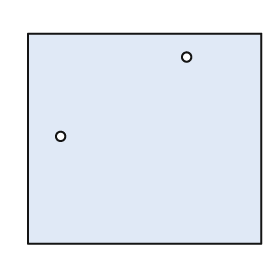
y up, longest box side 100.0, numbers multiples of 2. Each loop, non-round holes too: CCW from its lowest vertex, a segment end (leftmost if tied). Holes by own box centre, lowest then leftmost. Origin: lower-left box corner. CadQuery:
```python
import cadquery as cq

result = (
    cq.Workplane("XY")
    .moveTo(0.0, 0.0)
    .lineTo(100.0, 0.0)
    .lineTo(100.0, 90.0)
    .lineTo(0.0, 90.0)
    .close()
    .moveTo(14.0, 46.0)
    .circle(2.0)
    .moveTo(68.0, 80.0)
    .circle(2.0)
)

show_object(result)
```